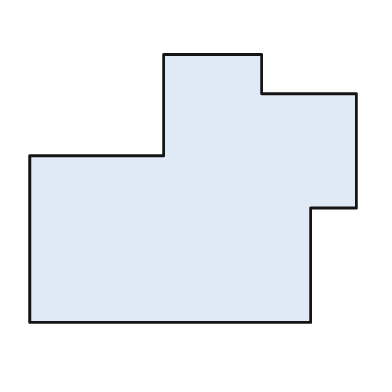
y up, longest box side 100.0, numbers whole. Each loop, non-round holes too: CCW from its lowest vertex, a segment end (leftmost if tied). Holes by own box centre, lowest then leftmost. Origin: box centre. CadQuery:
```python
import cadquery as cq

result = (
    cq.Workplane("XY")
    .moveTo(-50.0, -41.0)
    .lineTo(36.0, -41.0)
    .lineTo(36.0, -6.0)
    .lineTo(50.0, -6.0)
    .lineTo(50.0, 29.0)
    .lineTo(21.0, 29.0)
    .lineTo(21.0, 41.0)
    .lineTo(-9.0, 41.0)
    .lineTo(-9.0, 10.0)
    .lineTo(-50.0, 10.0)
    .close()
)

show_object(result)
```